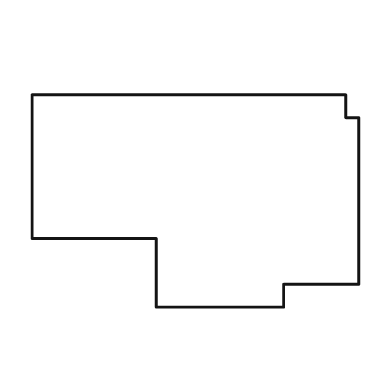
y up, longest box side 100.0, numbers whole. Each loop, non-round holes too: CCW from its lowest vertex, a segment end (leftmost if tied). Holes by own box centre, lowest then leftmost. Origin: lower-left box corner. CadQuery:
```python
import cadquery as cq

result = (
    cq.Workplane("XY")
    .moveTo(38.0, 0.0)
    .lineTo(77.0, 0.0)
    .lineTo(77.0, 7.0)
    .lineTo(100.0, 7.0)
    .lineTo(100.0, 58.0)
    .lineTo(96.0, 58.0)
    .lineTo(96.0, 65.0)
    .lineTo(0.0, 65.0)
    .lineTo(0.0, 21.0)
    .lineTo(38.0, 21.0)
    .close()
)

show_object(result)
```